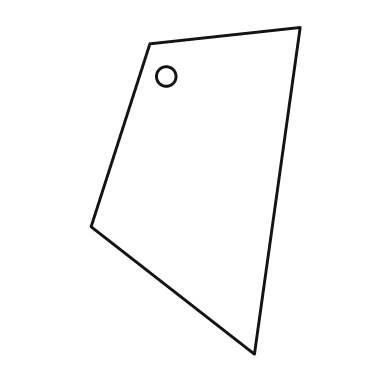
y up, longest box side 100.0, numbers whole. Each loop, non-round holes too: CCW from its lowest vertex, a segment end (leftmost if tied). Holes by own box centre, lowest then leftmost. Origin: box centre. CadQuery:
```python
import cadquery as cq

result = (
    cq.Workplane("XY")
    .moveTo(18.0, -50.0)
    .lineTo(32.0, 50.0)
    .lineTo(-14.0, 45.0)
    .lineTo(-32.0, -11.0)
    .close()
    .moveTo(-9.0, 35.0)
    .circle(3.0)
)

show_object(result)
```